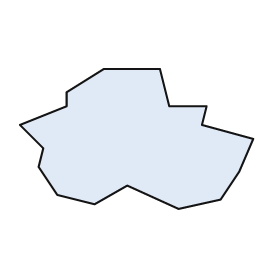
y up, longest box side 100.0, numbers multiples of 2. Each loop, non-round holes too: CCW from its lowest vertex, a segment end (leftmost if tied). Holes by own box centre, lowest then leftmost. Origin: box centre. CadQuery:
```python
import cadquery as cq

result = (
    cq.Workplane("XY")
    .moveTo(18.0, -30.0)
    .lineTo(36.0, -26.0)
    .lineTo(44.0, -14.0)
    .lineTo(50.0, 0.0)
    .lineTo(28.0, 6.0)
    .lineTo(30.0, 14.0)
    .lineTo(14.0, 14.0)
    .lineTo(10.0, 30.0)
    .lineTo(-14.0, 30.0)
    .lineTo(-30.0, 20.0)
    .lineTo(-30.0, 14.0)
    .lineTo(-50.0, 6.0)
    .lineTo(-40.0, -4.0)
    .lineTo(-42.0, -12.0)
    .lineTo(-34.0, -24.0)
    .lineTo(-18.0, -28.0)
    .lineTo(-4.0, -20.0)
    .close()
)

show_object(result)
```